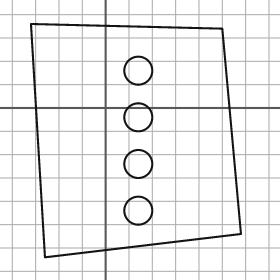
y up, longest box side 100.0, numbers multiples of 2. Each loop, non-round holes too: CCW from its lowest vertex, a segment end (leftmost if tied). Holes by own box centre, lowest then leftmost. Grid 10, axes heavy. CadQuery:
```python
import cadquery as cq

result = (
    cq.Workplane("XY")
    .moveTo(-26.0, -64.0)
    .lineTo(58.0, -54.0)
    .lineTo(50.0, 34.0)
    .lineTo(-32.0, 36.0)
    .close()
    .moveTo(14.0, -44.0)
    .circle(6.0)
    .moveTo(14.0, -24.0)
    .circle(6.0)
    .moveTo(14.0, -4.0)
    .circle(6.0)
    .moveTo(14.0, 16.0)
    .circle(6.0)
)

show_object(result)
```